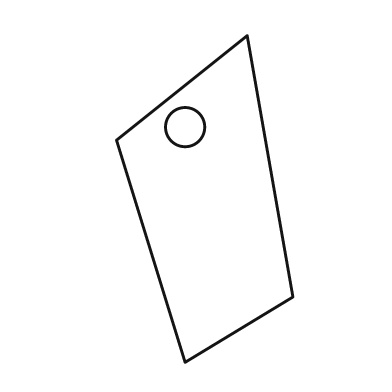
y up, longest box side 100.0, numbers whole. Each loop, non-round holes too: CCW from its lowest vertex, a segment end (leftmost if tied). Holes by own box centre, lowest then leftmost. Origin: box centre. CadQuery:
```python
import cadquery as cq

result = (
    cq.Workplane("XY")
    .moveTo(-6.0, -50.0)
    .lineTo(27.0, -30.0)
    .lineTo(13.0, 50.0)
    .lineTo(-27.0, 18.0)
    .close()
    .moveTo(-6.0, 22.0)
    .circle(6.0)
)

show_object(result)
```